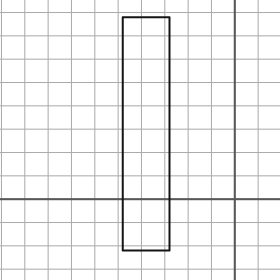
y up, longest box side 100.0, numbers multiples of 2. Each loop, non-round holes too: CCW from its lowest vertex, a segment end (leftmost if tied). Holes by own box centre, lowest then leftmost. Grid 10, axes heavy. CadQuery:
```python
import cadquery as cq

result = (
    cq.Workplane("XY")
    .moveTo(-48.0, -22.0)
    .lineTo(-28.0, -22.0)
    .lineTo(-28.0, 78.0)
    .lineTo(-48.0, 78.0)
    .close()
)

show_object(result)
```